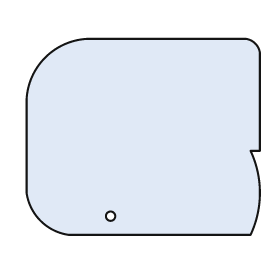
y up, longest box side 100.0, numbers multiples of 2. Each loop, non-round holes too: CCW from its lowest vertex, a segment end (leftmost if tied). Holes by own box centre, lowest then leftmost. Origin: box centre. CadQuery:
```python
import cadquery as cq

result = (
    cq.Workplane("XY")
    .moveTo(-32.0, -42.0)
    .lineTo(46.0, -42.0)
    .threePointArc((50.0, -24.0), (46.0, -6.0))
    .lineTo(50.0, -6.0)
    .lineTo(50.0, 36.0)
    .threePointArc((48.0, 40.0), (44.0, 42.0))
    .lineTo(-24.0, 42.0)
    .threePointArc((-42.0, 34.0), (-50.0, 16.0))
    .lineTo(-50.0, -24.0)
    .threePointArc((-44.0, -36.0), (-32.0, -42.0))
    .close()
    .moveTo(-14.0, -34.0)
    .circle(2.0)
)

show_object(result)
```